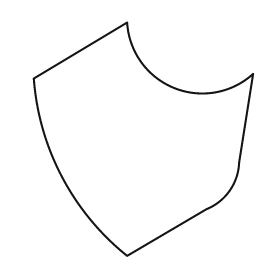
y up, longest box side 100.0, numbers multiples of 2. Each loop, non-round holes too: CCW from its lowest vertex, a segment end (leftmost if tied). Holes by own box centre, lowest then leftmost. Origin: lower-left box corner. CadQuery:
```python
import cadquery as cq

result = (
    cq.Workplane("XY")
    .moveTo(40.0, 0.0)
    .lineTo(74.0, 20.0)
    .threePointArc((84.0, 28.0), (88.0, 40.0))
    .lineTo(94.0, 78.0)
    .threePointArc((60.0, 72.0), (40.0, 100.0))
    .lineTo(0.0, 76.0)
    .threePointArc((12.0, 34.0), (40.0, 0.0))
    .close()
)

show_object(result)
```